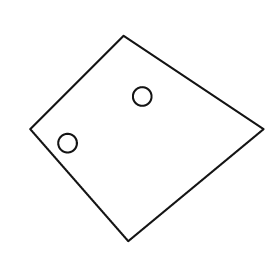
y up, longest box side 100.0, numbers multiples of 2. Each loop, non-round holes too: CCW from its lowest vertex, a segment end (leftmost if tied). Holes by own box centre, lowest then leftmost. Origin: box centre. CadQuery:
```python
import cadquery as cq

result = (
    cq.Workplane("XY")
    .moveTo(-8.0, -44.0)
    .lineTo(50.0, 4.0)
    .lineTo(-10.0, 44.0)
    .lineTo(-50.0, 4.0)
    .close()
    .moveTo(-34.0, -2.0)
    .circle(4.0)
    .moveTo(-2.0, 18.0)
    .circle(4.0)
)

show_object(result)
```